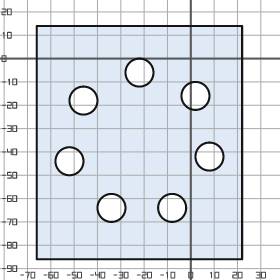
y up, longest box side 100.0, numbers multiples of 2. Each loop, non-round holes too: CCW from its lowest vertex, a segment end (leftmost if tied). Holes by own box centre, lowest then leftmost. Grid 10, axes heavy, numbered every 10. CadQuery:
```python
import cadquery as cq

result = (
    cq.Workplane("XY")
    .moveTo(-66.0, -86.0)
    .lineTo(22.0, -86.0)
    .lineTo(22.0, 14.0)
    .lineTo(-66.0, 14.0)
    .close()
    .moveTo(-34.0, -64.0)
    .circle(6.0)
    .moveTo(-8.0, -64.0)
    .circle(6.0)
    .moveTo(-52.0, -44.0)
    .circle(6.0)
    .moveTo(8.0, -42.0)
    .circle(6.0)
    .moveTo(-46.0, -18.0)
    .circle(6.0)
    .moveTo(2.0, -16.0)
    .circle(6.0)
    .moveTo(-22.0, -6.0)
    .circle(6.0)
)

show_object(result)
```